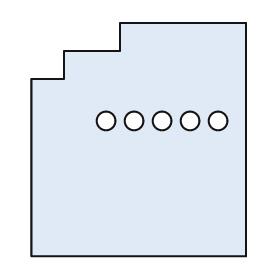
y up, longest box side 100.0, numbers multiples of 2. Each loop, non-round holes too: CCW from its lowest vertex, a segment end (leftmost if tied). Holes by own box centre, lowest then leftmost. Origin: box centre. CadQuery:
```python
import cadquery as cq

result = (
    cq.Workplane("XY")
    .moveTo(-46.0, -50.0)
    .lineTo(46.0, -50.0)
    .lineTo(46.0, 50.0)
    .lineTo(-8.0, 50.0)
    .lineTo(-8.0, 38.0)
    .lineTo(-32.0, 38.0)
    .lineTo(-32.0, 26.0)
    .lineTo(-46.0, 26.0)
    .close()
    .moveTo(-14.0, 8.0)
    .circle(4.0)
    .moveTo(-2.0, 8.0)
    .circle(4.0)
    .moveTo(10.0, 8.0)
    .circle(4.0)
    .moveTo(22.0, 8.0)
    .circle(4.0)
    .moveTo(34.0, 8.0)
    .circle(4.0)
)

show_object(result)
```